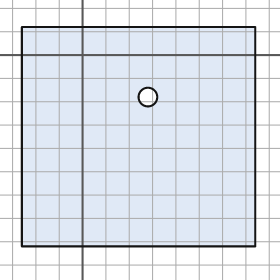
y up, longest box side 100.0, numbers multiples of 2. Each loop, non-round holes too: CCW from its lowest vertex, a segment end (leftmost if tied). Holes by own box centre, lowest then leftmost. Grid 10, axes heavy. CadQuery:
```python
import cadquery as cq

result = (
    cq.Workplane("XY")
    .moveTo(-26.0, -82.0)
    .lineTo(74.0, -82.0)
    .lineTo(74.0, 12.0)
    .lineTo(-26.0, 12.0)
    .close()
    .moveTo(28.0, -18.0)
    .circle(4.0)
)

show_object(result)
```